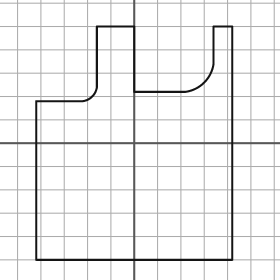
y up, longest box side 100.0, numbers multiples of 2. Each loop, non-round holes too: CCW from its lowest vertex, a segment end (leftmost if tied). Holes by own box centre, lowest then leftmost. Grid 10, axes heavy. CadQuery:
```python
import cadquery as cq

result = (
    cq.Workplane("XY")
    .moveTo(-42.0, -50.0)
    .lineTo(42.0, -50.0)
    .lineTo(42.0, 50.0)
    .lineTo(34.0, 50.0)
    .lineTo(34.0, 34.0)
    .threePointArc((30.0, 26.0), (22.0, 22.0))
    .lineTo(0.0, 22.0)
    .lineTo(0.0, 50.0)
    .lineTo(-16.0, 50.0)
    .lineTo(-16.0, 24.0)
    .threePointArc((-18.0, 20.0), (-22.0, 18.0))
    .lineTo(-42.0, 18.0)
    .close()
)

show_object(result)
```